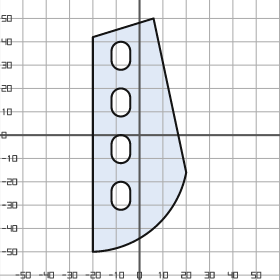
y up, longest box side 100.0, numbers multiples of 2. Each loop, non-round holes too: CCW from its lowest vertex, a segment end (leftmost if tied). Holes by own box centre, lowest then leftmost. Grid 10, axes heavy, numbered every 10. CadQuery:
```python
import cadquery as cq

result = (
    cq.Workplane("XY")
    .moveTo(-20.0, -50.0)
    .threePointArc((6.0, -40.0), (20.0, -16.0))
    .lineTo(6.0, 50.0)
    .lineTo(-20.0, 42.0)
    .close()
    .moveTo(-12.0, -28.0)
    .threePointArc((-8.0, -32.0), (-4.0, -28.0))
    .lineTo(-4.0, -24.0)
    .threePointArc((-8.0, -20.0), (-12.0, -24.0))
    .close()
    .moveTo(-12.0, -8.0)
    .threePointArc((-8.0, -12.0), (-4.0, -8.0))
    .lineTo(-4.0, -4.0)
    .threePointArc((-8.0, 0.0), (-12.0, -4.0))
    .close()
    .moveTo(-12.0, 12.0)
    .threePointArc((-8.0, 8.0), (-4.0, 12.0))
    .lineTo(-4.0, 16.0)
    .threePointArc((-8.0, 20.0), (-12.0, 16.0))
    .close()
    .moveTo(-12.0, 32.0)
    .threePointArc((-8.0, 28.0), (-4.0, 32.0))
    .lineTo(-4.0, 36.0)
    .threePointArc((-8.0, 40.0), (-12.0, 36.0))
    .close()
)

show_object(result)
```